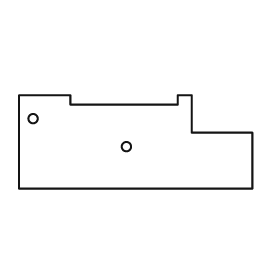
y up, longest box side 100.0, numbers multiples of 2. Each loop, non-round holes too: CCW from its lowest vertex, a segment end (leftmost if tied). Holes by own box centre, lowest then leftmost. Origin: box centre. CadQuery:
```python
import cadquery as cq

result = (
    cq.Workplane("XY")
    .moveTo(-50.0, -20.0)
    .lineTo(50.0, -20.0)
    .lineTo(50.0, 4.0)
    .lineTo(24.0, 4.0)
    .lineTo(24.0, 20.0)
    .lineTo(18.0, 20.0)
    .lineTo(18.0, 16.0)
    .lineTo(-28.0, 16.0)
    .lineTo(-28.0, 20.0)
    .lineTo(-50.0, 20.0)
    .close()
    .moveTo(-4.0, -2.0)
    .circle(2.0)
    .moveTo(-44.0, 10.0)
    .circle(2.0)
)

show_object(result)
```